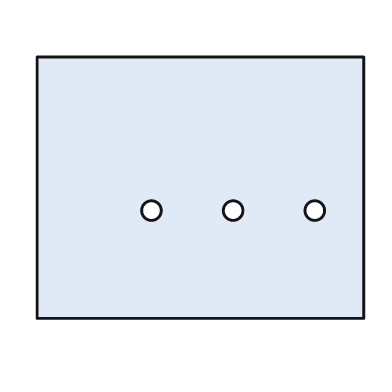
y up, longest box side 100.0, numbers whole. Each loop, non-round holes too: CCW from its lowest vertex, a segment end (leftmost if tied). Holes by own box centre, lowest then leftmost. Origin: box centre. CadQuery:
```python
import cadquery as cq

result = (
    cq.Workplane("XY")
    .moveTo(-50.0, -40.0)
    .lineTo(50.0, -40.0)
    .lineTo(50.0, 40.0)
    .lineTo(-50.0, 40.0)
    .close()
    .moveTo(-15.0, -7.0)
    .circle(3.0)
    .moveTo(10.0, -7.0)
    .circle(3.0)
    .moveTo(35.0, -7.0)
    .circle(3.0)
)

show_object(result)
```